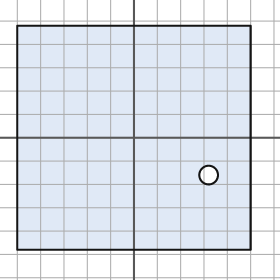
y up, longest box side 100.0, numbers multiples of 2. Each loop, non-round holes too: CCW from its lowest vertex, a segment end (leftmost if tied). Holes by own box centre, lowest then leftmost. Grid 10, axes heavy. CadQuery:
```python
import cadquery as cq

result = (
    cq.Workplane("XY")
    .moveTo(-50.0, -48.0)
    .lineTo(50.0, -48.0)
    .lineTo(50.0, 48.0)
    .lineTo(-50.0, 48.0)
    .close()
    .moveTo(32.0, -16.0)
    .circle(4.0)
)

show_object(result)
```